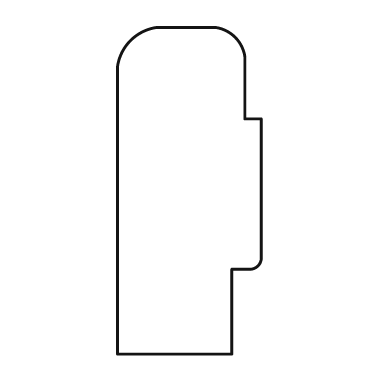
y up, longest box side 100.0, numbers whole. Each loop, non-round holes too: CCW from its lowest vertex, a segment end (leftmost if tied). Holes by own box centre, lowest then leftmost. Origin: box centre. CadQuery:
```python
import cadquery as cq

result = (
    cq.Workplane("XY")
    .moveTo(-22.0, -50.0)
    .lineTo(13.0, -50.0)
    .lineTo(13.0, -24.0)
    .lineTo(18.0, -24.0)
    .threePointArc((21.0, -23.0), (22.0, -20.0))
    .lineTo(22.0, 22.0)
    .lineTo(17.0, 22.0)
    .lineTo(17.0, 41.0)
    .threePointArc((14.0, 47.0), (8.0, 50.0))
    .lineTo(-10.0, 50.0)
    .threePointArc((-18.0, 46.0), (-22.0, 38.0))
    .close()
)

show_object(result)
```